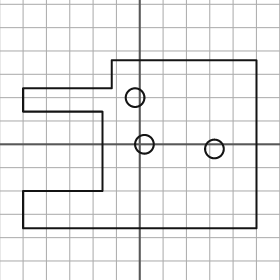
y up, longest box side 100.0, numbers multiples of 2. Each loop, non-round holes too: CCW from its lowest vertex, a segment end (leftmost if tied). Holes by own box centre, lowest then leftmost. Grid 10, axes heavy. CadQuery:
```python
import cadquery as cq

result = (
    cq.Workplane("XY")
    .moveTo(-50.0, -36.0)
    .lineTo(50.0, -36.0)
    .lineTo(50.0, 36.0)
    .lineTo(-12.0, 36.0)
    .lineTo(-12.0, 24.0)
    .lineTo(-50.0, 24.0)
    .lineTo(-50.0, 14.0)
    .lineTo(-16.0, 14.0)
    .lineTo(-16.0, -20.0)
    .lineTo(-50.0, -20.0)
    .close()
    .moveTo(32.0, -2.0)
    .circle(4.0)
    .moveTo(2.0, 0.0)
    .circle(4.0)
    .moveTo(-2.0, 20.0)
    .circle(4.0)
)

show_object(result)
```